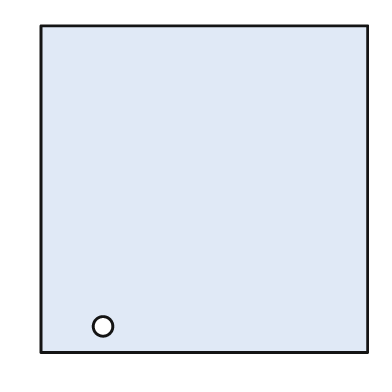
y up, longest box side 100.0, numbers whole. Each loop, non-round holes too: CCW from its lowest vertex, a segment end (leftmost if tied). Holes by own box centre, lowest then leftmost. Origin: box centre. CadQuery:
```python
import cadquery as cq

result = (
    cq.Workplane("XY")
    .moveTo(-50.0, -50.0)
    .lineTo(50.0, -50.0)
    .lineTo(50.0, 50.0)
    .lineTo(-50.0, 50.0)
    .close()
    .moveTo(-31.0, -42.0)
    .circle(3.0)
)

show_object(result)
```